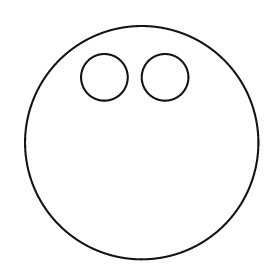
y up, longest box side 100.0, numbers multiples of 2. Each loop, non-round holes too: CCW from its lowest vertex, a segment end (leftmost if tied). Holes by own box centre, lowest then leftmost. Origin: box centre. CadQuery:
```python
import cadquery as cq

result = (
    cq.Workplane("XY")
    .moveTo(0.0, 0.0)
    .circle(50.0)
    .moveTo(-16.0, 28.0)
    .circle(10.0)
    .moveTo(10.0, 28.0)
    .circle(10.0)
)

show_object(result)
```